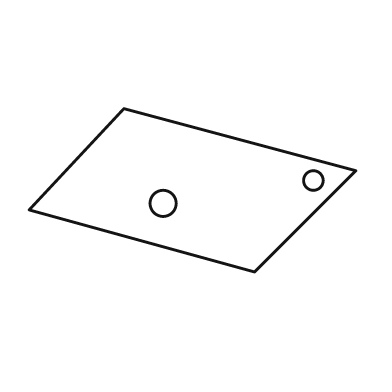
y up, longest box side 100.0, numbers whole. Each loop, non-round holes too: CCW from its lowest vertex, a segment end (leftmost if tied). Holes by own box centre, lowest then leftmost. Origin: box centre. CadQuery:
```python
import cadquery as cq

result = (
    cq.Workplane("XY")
    .moveTo(19.0, -25.0)
    .lineTo(50.0, 6.0)
    .lineTo(-21.0, 25.0)
    .lineTo(-50.0, -6.0)
    .close()
    .moveTo(-9.0, -4.0)
    .circle(4.0)
    .moveTo(37.0, 3.0)
    .circle(3.0)
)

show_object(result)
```